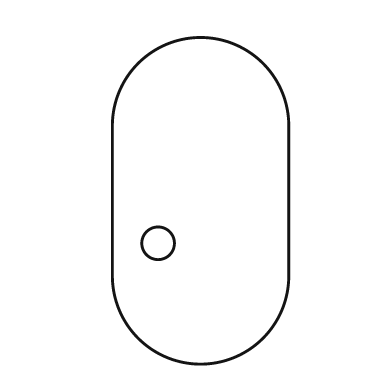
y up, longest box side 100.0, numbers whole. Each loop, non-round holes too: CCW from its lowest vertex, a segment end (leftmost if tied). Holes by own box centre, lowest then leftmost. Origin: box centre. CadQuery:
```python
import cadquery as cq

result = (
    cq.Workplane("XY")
    .moveTo(-27.0, -23.0)
    .threePointArc((0.0, -50.0), (27.0, -23.0))
    .lineTo(27.0, 23.0)
    .threePointArc((0.0, 50.0), (-27.0, 23.0))
    .close()
    .moveTo(-13.0, -13.0)
    .circle(5.0)
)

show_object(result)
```